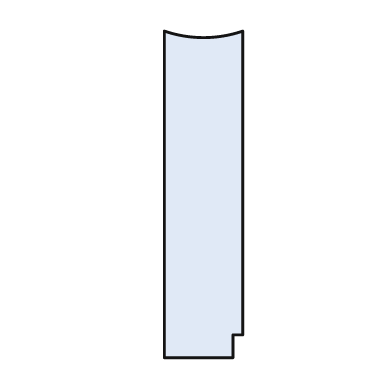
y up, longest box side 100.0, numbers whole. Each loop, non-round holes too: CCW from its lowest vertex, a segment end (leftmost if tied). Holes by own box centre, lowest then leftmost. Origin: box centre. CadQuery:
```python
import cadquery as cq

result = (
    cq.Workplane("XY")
    .moveTo(-12.0, -50.0)
    .lineTo(9.0, -50.0)
    .lineTo(9.0, -43.0)
    .lineTo(12.0, -43.0)
    .lineTo(12.0, 50.0)
    .threePointArc((0.0, 48.0), (-12.0, 50.0))
    .close()
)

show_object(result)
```